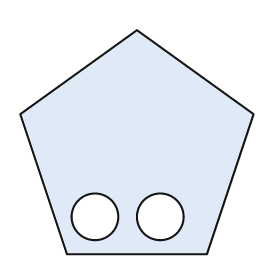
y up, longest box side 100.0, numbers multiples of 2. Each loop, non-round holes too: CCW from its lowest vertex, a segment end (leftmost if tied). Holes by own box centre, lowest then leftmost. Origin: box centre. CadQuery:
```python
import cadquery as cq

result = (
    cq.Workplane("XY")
    .moveTo(-30.0, -48.0)
    .lineTo(30.0, -48.0)
    .lineTo(50.0, 12.0)
    .lineTo(0.0, 48.0)
    .lineTo(-50.0, 12.0)
    .close()
    .moveTo(-18.0, -32.0)
    .circle(10.0)
    .moveTo(10.0, -32.0)
    .circle(10.0)
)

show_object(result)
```